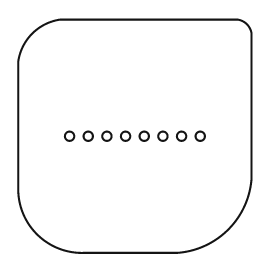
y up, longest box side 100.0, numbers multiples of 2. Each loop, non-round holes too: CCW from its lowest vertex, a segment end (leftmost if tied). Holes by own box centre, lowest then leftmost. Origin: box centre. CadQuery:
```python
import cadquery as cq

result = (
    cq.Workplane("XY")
    .moveTo(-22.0, -50.0)
    .lineTo(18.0, -50.0)
    .threePointArc((40.0, -40.0), (50.0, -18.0))
    .lineTo(50.0, 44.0)
    .threePointArc((48.0, 48.0), (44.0, 50.0))
    .lineTo(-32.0, 50.0)
    .threePointArc((-44.0, 44.0), (-50.0, 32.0))
    .lineTo(-50.0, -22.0)
    .threePointArc((-42.0, -42.0), (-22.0, -50.0))
    .close()
    .moveTo(-28.0, 0.0)
    .circle(2.0)
    .moveTo(-20.0, 0.0)
    .circle(2.0)
    .moveTo(-12.0, 0.0)
    .circle(2.0)
    .moveTo(-4.0, 0.0)
    .circle(2.0)
    .moveTo(4.0, 0.0)
    .circle(2.0)
    .moveTo(12.0, 0.0)
    .circle(2.0)
    .moveTo(20.0, 0.0)
    .circle(2.0)
    .moveTo(28.0, 0.0)
    .circle(2.0)
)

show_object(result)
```